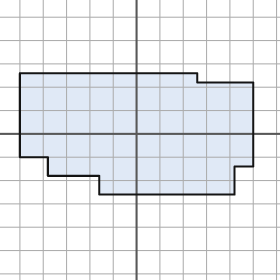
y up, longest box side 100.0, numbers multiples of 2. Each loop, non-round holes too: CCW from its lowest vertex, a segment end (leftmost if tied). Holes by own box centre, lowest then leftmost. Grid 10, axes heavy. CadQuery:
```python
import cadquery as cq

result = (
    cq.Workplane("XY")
    .moveTo(-16.0, -26.0)
    .lineTo(42.0, -26.0)
    .lineTo(42.0, -14.0)
    .lineTo(50.0, -14.0)
    .lineTo(50.0, 22.0)
    .lineTo(26.0, 22.0)
    .lineTo(26.0, 26.0)
    .lineTo(-50.0, 26.0)
    .lineTo(-50.0, -10.0)
    .lineTo(-38.0, -10.0)
    .lineTo(-38.0, -18.0)
    .lineTo(-16.0, -18.0)
    .close()
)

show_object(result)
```